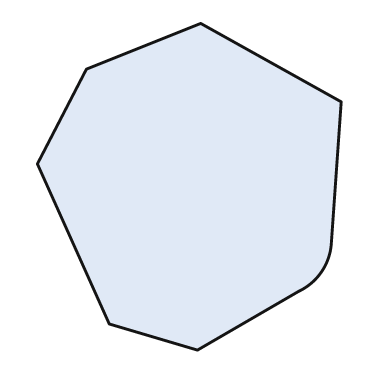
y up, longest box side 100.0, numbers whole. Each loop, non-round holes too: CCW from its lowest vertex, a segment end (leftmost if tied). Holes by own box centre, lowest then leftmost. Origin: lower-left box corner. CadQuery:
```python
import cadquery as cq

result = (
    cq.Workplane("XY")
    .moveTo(49.0, 0.0)
    .lineTo(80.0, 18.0)
    .threePointArc((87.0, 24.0), (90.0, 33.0))
    .lineTo(93.0, 76.0)
    .lineTo(50.0, 100.0)
    .lineTo(15.0, 86.0)
    .lineTo(0.0, 57.0)
    .lineTo(22.0, 8.0)
    .close()
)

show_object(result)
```